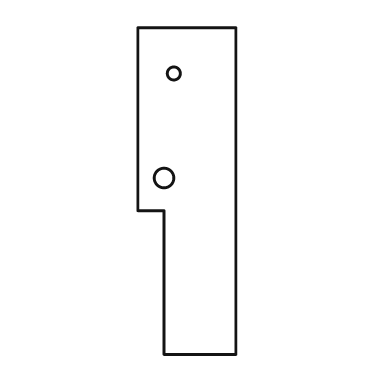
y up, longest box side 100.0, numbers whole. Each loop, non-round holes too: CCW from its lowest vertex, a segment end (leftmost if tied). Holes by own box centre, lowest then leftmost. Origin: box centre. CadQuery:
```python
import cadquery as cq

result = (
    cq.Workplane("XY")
    .moveTo(-7.0, -50.0)
    .lineTo(15.0, -50.0)
    .lineTo(15.0, 50.0)
    .lineTo(-15.0, 50.0)
    .lineTo(-15.0, -6.0)
    .lineTo(-7.0, -6.0)
    .close()
    .moveTo(-7.0, 4.0)
    .circle(3.0)
    .moveTo(-4.0, 36.0)
    .circle(2.0)
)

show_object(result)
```